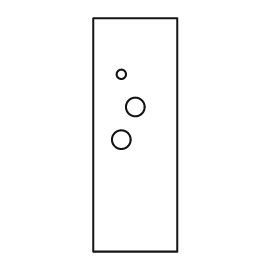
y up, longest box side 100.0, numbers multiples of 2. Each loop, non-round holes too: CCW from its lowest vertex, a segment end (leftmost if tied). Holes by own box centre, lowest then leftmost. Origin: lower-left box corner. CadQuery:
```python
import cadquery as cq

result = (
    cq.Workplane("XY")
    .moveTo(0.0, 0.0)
    .lineTo(36.0, 0.0)
    .lineTo(36.0, 100.0)
    .lineTo(0.0, 100.0)
    .close()
    .moveTo(12.0, 48.0)
    .circle(4.0)
    .moveTo(18.0, 62.0)
    .circle(4.0)
    .moveTo(12.0, 76.0)
    .circle(2.0)
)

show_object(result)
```